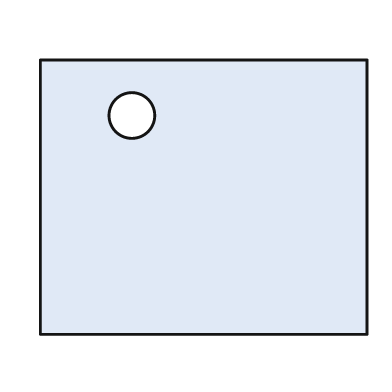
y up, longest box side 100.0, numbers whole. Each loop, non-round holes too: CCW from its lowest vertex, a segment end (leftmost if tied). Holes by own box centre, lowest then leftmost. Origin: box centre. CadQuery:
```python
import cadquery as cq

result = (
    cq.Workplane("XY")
    .moveTo(-50.0, -42.0)
    .lineTo(50.0, -42.0)
    .lineTo(50.0, 42.0)
    .lineTo(-50.0, 42.0)
    .close()
    .moveTo(-22.0, 25.0)
    .circle(7.0)
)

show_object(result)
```